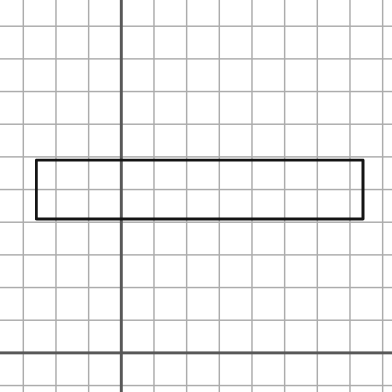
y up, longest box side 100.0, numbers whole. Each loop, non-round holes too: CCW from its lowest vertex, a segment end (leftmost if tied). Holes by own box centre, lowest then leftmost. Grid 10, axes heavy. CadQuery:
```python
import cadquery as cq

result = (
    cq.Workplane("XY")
    .moveTo(-26.0, 41.0)
    .lineTo(74.0, 41.0)
    .lineTo(74.0, 59.0)
    .lineTo(-26.0, 59.0)
    .close()
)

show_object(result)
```